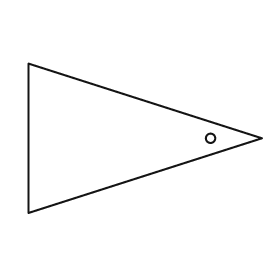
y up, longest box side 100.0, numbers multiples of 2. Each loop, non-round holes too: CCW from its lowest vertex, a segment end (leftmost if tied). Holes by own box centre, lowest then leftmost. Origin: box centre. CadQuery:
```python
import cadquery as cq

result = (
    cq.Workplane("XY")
    .moveTo(-50.0, -32.0)
    .lineTo(50.0, 0.0)
    .lineTo(-50.0, 32.0)
    .close()
    .moveTo(28.0, 0.0)
    .circle(2.0)
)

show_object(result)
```